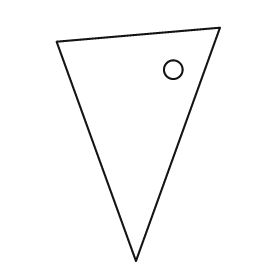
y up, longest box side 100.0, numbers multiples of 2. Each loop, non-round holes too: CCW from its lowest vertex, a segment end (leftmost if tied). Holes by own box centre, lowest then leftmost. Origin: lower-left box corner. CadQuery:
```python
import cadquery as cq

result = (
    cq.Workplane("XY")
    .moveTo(34.0, 0.0)
    .lineTo(70.0, 100.0)
    .lineTo(0.0, 94.0)
    .close()
    .moveTo(50.0, 82.0)
    .circle(4.0)
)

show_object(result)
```